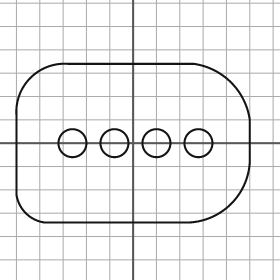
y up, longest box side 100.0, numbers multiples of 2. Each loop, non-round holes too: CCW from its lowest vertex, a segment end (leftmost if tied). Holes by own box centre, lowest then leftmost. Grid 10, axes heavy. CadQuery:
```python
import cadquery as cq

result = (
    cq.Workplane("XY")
    .moveTo(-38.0, -34.0)
    .lineTo(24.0, -34.0)
    .threePointArc((42.0, -26.0), (50.0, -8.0))
    .lineTo(50.0, 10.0)
    .threePointArc((42.0, 26.0), (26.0, 34.0))
    .lineTo(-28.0, 34.0)
    .threePointArc((-44.0, 28.0), (-50.0, 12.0))
    .lineTo(-50.0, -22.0)
    .threePointArc((-46.0, -30.0), (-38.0, -34.0))
    .close()
    .moveTo(-26.0, 0.0)
    .circle(6.0)
    .moveTo(-8.0, 0.0)
    .circle(6.0)
    .moveTo(10.0, 0.0)
    .circle(6.0)
    .moveTo(28.0, 0.0)
    .circle(6.0)
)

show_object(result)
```